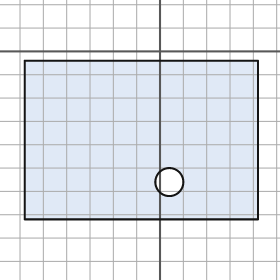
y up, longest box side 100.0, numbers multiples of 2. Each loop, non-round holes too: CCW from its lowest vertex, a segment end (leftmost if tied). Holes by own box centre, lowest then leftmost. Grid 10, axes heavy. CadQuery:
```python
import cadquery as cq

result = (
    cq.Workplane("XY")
    .moveTo(-58.0, -72.0)
    .lineTo(42.0, -72.0)
    .lineTo(42.0, -4.0)
    .lineTo(-58.0, -4.0)
    .close()
    .moveTo(4.0, -56.0)
    .circle(6.0)
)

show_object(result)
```